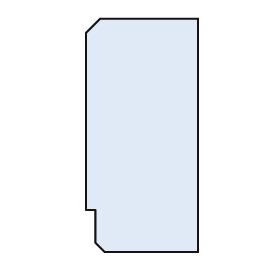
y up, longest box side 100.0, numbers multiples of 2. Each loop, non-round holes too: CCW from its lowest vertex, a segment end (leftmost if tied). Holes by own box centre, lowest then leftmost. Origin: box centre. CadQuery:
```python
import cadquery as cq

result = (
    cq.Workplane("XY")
    .moveTo(-16.0, -50.0)
    .lineTo(24.0, -50.0)
    .lineTo(24.0, 50.0)
    .lineTo(-18.0, 50.0)
    .lineTo(-24.0, 44.0)
    .lineTo(-24.0, -32.0)
    .lineTo(-20.0, -32.0)
    .lineTo(-20.0, -46.0)
    .close()
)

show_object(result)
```